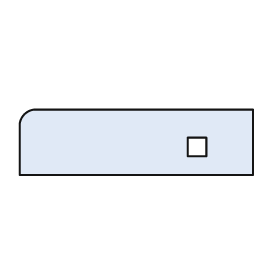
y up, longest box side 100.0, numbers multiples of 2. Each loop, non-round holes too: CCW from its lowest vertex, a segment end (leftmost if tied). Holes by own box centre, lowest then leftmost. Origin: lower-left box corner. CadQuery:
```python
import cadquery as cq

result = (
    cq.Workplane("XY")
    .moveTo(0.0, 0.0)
    .lineTo(100.0, 0.0)
    .lineTo(100.0, 28.0)
    .lineTo(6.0, 28.0)
    .threePointArc((2.0, 26.0), (0.0, 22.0))
    .close()
    .moveTo(72.0, 8.0)
    .lineTo(80.0, 8.0)
    .lineTo(80.0, 16.0)
    .lineTo(72.0, 16.0)
    .close()
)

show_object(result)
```